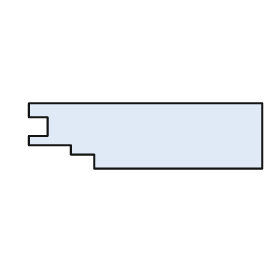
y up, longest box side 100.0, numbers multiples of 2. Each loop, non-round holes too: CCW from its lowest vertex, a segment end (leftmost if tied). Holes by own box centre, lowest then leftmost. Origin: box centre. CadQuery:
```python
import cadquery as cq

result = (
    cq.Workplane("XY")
    .moveTo(-22.0, -14.0)
    .lineTo(50.0, -14.0)
    .lineTo(50.0, 14.0)
    .lineTo(-50.0, 14.0)
    .lineTo(-50.0, 8.0)
    .lineTo(-42.0, 8.0)
    .lineTo(-42.0, 0.0)
    .lineTo(-50.0, 0.0)
    .lineTo(-50.0, -4.0)
    .lineTo(-32.0, -4.0)
    .lineTo(-32.0, -8.0)
    .lineTo(-22.0, -8.0)
    .close()
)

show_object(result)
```